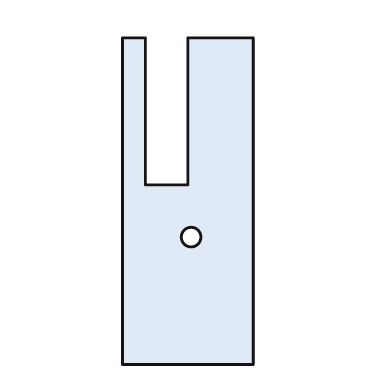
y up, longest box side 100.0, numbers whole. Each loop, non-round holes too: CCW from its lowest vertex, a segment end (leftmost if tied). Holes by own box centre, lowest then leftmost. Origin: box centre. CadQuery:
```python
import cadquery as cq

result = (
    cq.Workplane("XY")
    .moveTo(-20.0, -50.0)
    .lineTo(20.0, -50.0)
    .lineTo(20.0, 50.0)
    .lineTo(0.0, 50.0)
    .lineTo(0.0, 5.0)
    .lineTo(-13.0, 5.0)
    .lineTo(-13.0, 50.0)
    .lineTo(-20.0, 50.0)
    .close()
    .moveTo(1.0, -11.0)
    .circle(3.0)
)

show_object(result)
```